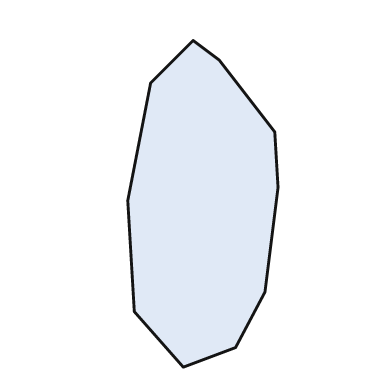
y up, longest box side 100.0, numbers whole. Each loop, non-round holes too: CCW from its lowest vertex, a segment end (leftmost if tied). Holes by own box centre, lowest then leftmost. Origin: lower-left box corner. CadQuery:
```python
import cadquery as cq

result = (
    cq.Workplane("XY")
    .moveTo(17.0, 0.0)
    .lineTo(33.0, 6.0)
    .lineTo(42.0, 23.0)
    .lineTo(46.0, 55.0)
    .lineTo(45.0, 72.0)
    .lineTo(28.0, 94.0)
    .lineTo(20.0, 100.0)
    .lineTo(7.0, 87.0)
    .lineTo(0.0, 51.0)
    .lineTo(2.0, 17.0)
    .close()
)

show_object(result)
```